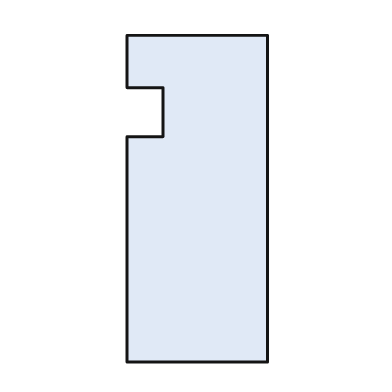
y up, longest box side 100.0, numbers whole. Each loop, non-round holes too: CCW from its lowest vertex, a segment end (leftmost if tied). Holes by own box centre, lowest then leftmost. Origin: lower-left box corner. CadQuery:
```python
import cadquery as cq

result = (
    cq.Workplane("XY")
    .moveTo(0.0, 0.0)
    .lineTo(43.0, 0.0)
    .lineTo(43.0, 100.0)
    .lineTo(0.0, 100.0)
    .lineTo(0.0, 84.0)
    .lineTo(11.0, 84.0)
    .lineTo(11.0, 69.0)
    .lineTo(0.0, 69.0)
    .close()
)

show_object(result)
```